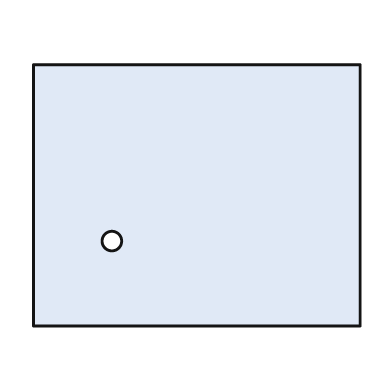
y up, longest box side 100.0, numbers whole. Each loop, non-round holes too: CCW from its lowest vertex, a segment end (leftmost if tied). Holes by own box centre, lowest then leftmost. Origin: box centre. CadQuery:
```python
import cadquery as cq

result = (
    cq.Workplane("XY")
    .moveTo(-50.0, -40.0)
    .lineTo(50.0, -40.0)
    .lineTo(50.0, 40.0)
    .lineTo(-50.0, 40.0)
    .close()
    .moveTo(-26.0, -14.0)
    .circle(3.0)
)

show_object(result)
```